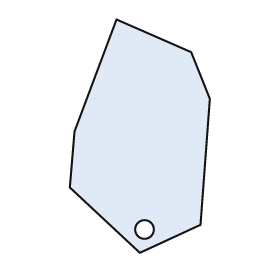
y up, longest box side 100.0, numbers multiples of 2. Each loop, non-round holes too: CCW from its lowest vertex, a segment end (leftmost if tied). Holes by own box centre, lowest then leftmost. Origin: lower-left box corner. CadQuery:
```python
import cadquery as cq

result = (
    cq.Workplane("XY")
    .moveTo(30.0, 0.0)
    .lineTo(56.0, 12.0)
    .lineTo(60.0, 66.0)
    .lineTo(52.0, 86.0)
    .lineTo(20.0, 100.0)
    .lineTo(2.0, 52.0)
    .lineTo(0.0, 28.0)
    .close()
    .moveTo(32.0, 10.0)
    .circle(4.0)
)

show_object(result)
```